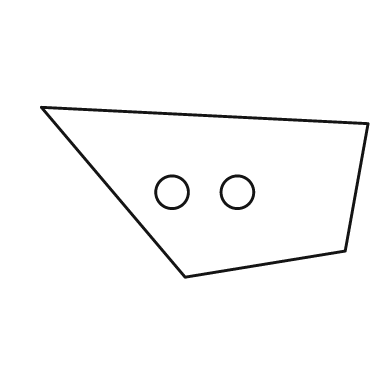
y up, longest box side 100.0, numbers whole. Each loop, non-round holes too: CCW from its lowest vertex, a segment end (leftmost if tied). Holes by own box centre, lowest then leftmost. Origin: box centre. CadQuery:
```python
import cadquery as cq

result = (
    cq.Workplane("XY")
    .moveTo(-6.0, -26.0)
    .lineTo(43.0, -18.0)
    .lineTo(50.0, 21.0)
    .lineTo(-50.0, 26.0)
    .close()
    .moveTo(-10.0, 0.0)
    .circle(5.0)
    .moveTo(10.0, 0.0)
    .circle(5.0)
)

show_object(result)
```